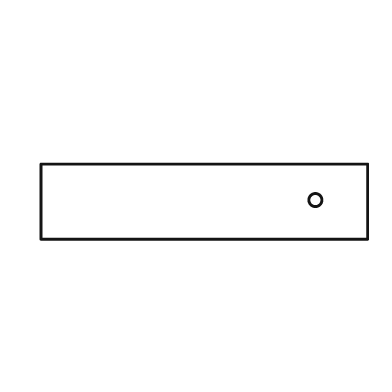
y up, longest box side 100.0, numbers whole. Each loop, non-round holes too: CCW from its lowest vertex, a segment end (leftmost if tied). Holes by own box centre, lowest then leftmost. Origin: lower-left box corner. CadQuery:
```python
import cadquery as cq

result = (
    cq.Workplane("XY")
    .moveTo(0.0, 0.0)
    .lineTo(100.0, 0.0)
    .lineTo(100.0, 23.0)
    .lineTo(0.0, 23.0)
    .close()
    .moveTo(84.0, 12.0)
    .circle(2.0)
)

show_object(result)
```